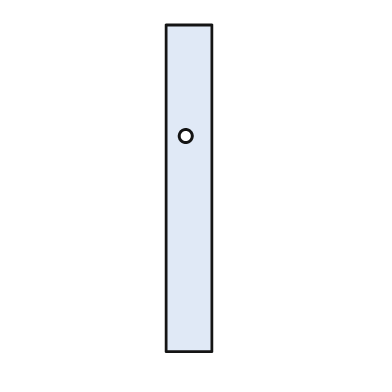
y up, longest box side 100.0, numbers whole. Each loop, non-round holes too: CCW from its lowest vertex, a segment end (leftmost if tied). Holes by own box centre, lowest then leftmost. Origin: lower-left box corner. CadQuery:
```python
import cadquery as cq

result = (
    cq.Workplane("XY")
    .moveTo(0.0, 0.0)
    .lineTo(14.0, 0.0)
    .lineTo(14.0, 100.0)
    .lineTo(0.0, 100.0)
    .close()
    .moveTo(6.0, 66.0)
    .circle(2.0)
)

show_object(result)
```